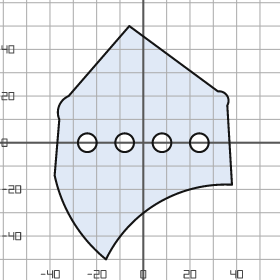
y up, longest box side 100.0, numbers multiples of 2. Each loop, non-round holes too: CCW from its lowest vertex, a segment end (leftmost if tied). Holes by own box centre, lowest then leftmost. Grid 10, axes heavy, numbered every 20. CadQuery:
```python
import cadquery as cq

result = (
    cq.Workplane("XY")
    .moveTo(-16.0, -50.0)
    .threePointArc((6.0, -26.0), (38.0, -18.0))
    .lineTo(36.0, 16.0)
    .threePointArc((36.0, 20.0), (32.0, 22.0))
    .lineTo(-6.0, 50.0)
    .lineTo(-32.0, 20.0)
    .threePointArc((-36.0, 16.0), (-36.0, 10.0))
    .lineTo(-38.0, -14.0)
    .threePointArc((-30.0, -34.0), (-16.0, -50.0))
    .close()
    .moveTo(-24.0, 0.0)
    .circle(4.0)
    .moveTo(-8.0, 0.0)
    .circle(4.0)
    .moveTo(8.0, 0.0)
    .circle(4.0)
    .moveTo(24.0, 0.0)
    .circle(4.0)
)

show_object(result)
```